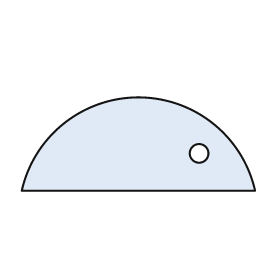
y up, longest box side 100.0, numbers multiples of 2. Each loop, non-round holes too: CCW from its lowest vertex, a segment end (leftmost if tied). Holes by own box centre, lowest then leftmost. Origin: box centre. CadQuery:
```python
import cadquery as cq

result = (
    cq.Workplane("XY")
    .moveTo(-50.0, -20.0)
    .lineTo(50.0, -20.0)
    .threePointArc((0.0, 20.0), (-50.0, -20.0))
    .close()
    .moveTo(26.0, -4.0)
    .circle(4.0)
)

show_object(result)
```